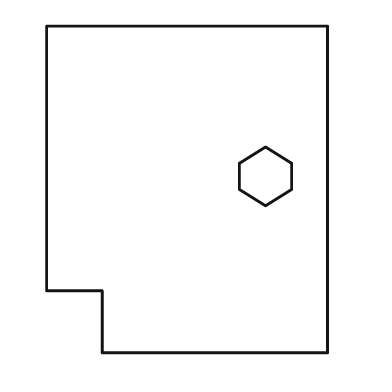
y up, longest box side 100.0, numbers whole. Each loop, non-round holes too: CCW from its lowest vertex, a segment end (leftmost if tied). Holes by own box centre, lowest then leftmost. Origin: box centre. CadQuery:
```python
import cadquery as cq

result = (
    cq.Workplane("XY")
    .moveTo(-26.0, -50.0)
    .lineTo(43.0, -50.0)
    .lineTo(43.0, 50.0)
    .lineTo(-43.0, 50.0)
    .lineTo(-43.0, -31.0)
    .lineTo(-26.0, -31.0)
    .close()
    .moveTo(24.0, -5.0)
    .lineTo(32.0, 0.0)
    .lineTo(32.0, 8.0)
    .lineTo(24.0, 13.0)
    .lineTo(16.0, 8.0)
    .lineTo(16.0, 0.0)
    .close()
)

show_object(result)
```